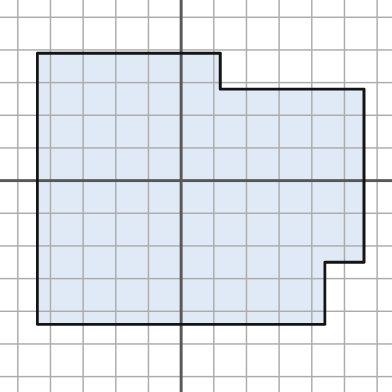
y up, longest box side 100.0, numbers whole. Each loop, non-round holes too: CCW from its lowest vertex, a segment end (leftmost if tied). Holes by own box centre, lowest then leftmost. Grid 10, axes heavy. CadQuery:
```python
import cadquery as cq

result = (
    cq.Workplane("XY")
    .moveTo(-44.0, -44.0)
    .lineTo(44.0, -44.0)
    .lineTo(44.0, -25.0)
    .lineTo(56.0, -25.0)
    .lineTo(56.0, 28.0)
    .lineTo(12.0, 28.0)
    .lineTo(12.0, 39.0)
    .lineTo(-44.0, 39.0)
    .close()
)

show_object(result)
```